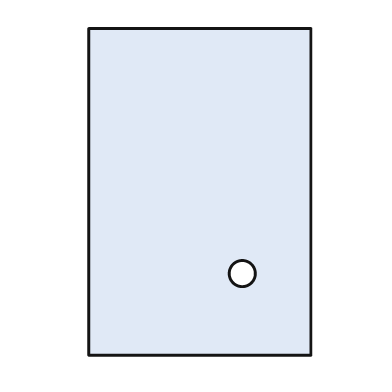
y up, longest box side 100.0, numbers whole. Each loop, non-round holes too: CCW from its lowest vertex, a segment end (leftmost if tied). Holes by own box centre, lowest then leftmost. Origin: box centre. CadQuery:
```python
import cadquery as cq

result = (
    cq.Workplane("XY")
    .moveTo(-34.0, -50.0)
    .lineTo(34.0, -50.0)
    .lineTo(34.0, 50.0)
    .lineTo(-34.0, 50.0)
    .close()
    .moveTo(13.0, -25.0)
    .circle(4.0)
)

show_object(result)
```